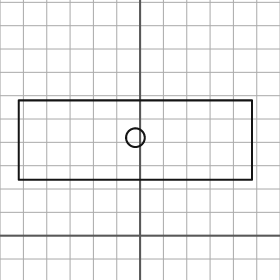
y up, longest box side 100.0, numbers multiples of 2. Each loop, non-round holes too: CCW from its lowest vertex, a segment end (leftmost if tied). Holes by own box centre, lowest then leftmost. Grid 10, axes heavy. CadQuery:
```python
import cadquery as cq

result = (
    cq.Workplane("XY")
    .moveTo(-52.0, 24.0)
    .lineTo(48.0, 24.0)
    .lineTo(48.0, 58.0)
    .lineTo(-52.0, 58.0)
    .close()
    .moveTo(-2.0, 42.0)
    .circle(4.0)
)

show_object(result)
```